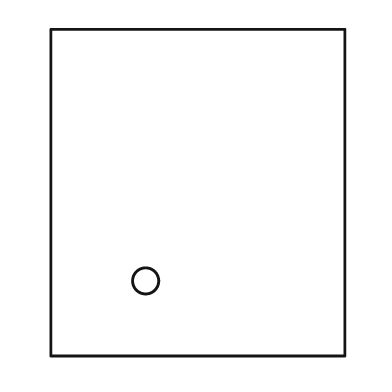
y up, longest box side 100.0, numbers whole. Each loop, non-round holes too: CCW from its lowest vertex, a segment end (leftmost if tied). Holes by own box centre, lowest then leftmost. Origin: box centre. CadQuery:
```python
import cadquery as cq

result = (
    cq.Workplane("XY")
    .moveTo(-45.0, -50.0)
    .lineTo(45.0, -50.0)
    .lineTo(45.0, 50.0)
    .lineTo(-45.0, 50.0)
    .close()
    .moveTo(-16.0, -27.0)
    .circle(4.0)
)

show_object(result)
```